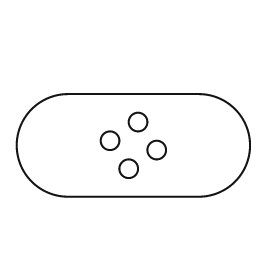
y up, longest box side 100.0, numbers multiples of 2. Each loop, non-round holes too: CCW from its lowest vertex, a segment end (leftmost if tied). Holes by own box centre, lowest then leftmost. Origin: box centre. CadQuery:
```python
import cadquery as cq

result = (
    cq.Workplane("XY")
    .moveTo(-28.0, -22.0)
    .lineTo(28.0, -22.0)
    .threePointArc((50.0, 0.0), (28.0, 22.0))
    .lineTo(-28.0, 22.0)
    .threePointArc((-50.0, 0.0), (-28.0, -22.0))
    .close()
    .moveTo(-2.0, -10.0)
    .circle(4.0)
    .moveTo(10.0, -2.0)
    .circle(4.0)
    .moveTo(-10.0, 2.0)
    .circle(4.0)
    .moveTo(2.0, 10.0)
    .circle(4.0)
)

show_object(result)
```